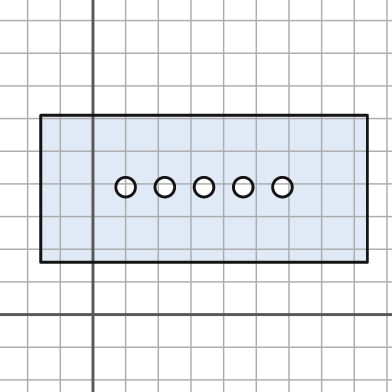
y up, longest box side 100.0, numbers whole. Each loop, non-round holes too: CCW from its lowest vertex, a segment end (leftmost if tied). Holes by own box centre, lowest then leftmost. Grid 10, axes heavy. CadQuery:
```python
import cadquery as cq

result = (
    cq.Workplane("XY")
    .moveTo(-16.0, 16.0)
    .lineTo(84.0, 16.0)
    .lineTo(84.0, 61.0)
    .lineTo(-16.0, 61.0)
    .close()
    .moveTo(10.0, 39.0)
    .circle(3.0)
    .moveTo(22.0, 39.0)
    .circle(3.0)
    .moveTo(34.0, 39.0)
    .circle(3.0)
    .moveTo(46.0, 39.0)
    .circle(3.0)
    .moveTo(58.0, 39.0)
    .circle(3.0)
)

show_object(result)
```